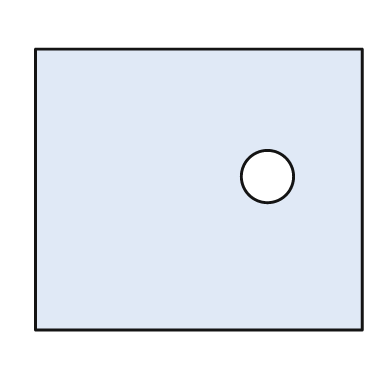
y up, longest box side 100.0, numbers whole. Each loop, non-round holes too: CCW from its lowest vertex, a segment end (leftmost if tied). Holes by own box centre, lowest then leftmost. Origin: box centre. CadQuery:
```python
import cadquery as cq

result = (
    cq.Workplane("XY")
    .moveTo(-50.0, -43.0)
    .lineTo(50.0, -43.0)
    .lineTo(50.0, 43.0)
    .lineTo(-50.0, 43.0)
    .close()
    .moveTo(21.0, 4.0)
    .circle(8.0)
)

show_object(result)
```